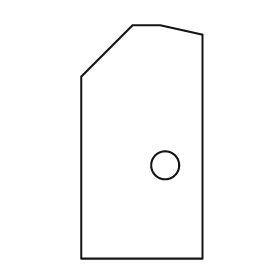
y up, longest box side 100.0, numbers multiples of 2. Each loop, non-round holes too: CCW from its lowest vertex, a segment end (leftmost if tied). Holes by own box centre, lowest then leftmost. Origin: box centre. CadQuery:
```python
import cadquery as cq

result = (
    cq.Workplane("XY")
    .moveTo(-26.0, -50.0)
    .lineTo(26.0, -50.0)
    .lineTo(26.0, 46.0)
    .lineTo(8.0, 50.0)
    .lineTo(-4.0, 50.0)
    .lineTo(-26.0, 28.0)
    .close()
    .moveTo(10.0, -10.0)
    .circle(6.0)
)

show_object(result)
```